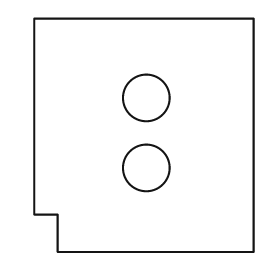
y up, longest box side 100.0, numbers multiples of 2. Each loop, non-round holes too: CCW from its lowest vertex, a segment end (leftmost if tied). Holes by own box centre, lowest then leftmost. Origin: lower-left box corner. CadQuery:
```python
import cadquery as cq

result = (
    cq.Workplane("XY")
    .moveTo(10.0, 0.0)
    .lineTo(94.0, 0.0)
    .lineTo(94.0, 100.0)
    .lineTo(0.0, 100.0)
    .lineTo(0.0, 16.0)
    .lineTo(10.0, 16.0)
    .close()
    .moveTo(48.0, 36.0)
    .circle(10.0)
    .moveTo(48.0, 66.0)
    .circle(10.0)
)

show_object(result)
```